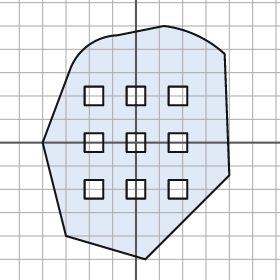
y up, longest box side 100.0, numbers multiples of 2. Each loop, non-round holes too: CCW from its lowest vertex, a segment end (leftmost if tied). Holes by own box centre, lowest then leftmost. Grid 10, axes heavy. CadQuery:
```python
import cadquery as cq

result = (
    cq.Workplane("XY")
    .moveTo(4.0, -50.0)
    .lineTo(40.0, -14.0)
    .lineTo(38.0, 38.0)
    .threePointArc((26.0, 46.0), (12.0, 50.0))
    .lineTo(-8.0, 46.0)
    .threePointArc((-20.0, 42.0), (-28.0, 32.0))
    .lineTo(-40.0, 0.0)
    .lineTo(-30.0, -40.0)
    .close()
    .moveTo(-22.0, -24.0)
    .lineTo(-14.0, -24.0)
    .lineTo(-14.0, -16.0)
    .lineTo(-22.0, -16.0)
    .close()
    .moveTo(-4.0, -24.0)
    .lineTo(4.0, -24.0)
    .lineTo(4.0, -16.0)
    .lineTo(-4.0, -16.0)
    .close()
    .moveTo(14.0, -24.0)
    .lineTo(22.0, -24.0)
    .lineTo(22.0, -16.0)
    .lineTo(14.0, -16.0)
    .close()
    .moveTo(-22.0, -4.0)
    .lineTo(-14.0, -4.0)
    .lineTo(-14.0, 4.0)
    .lineTo(-22.0, 4.0)
    .close()
    .moveTo(-4.0, -4.0)
    .lineTo(4.0, -4.0)
    .lineTo(4.0, 4.0)
    .lineTo(-4.0, 4.0)
    .close()
    .moveTo(14.0, -4.0)
    .lineTo(22.0, -4.0)
    .lineTo(22.0, 4.0)
    .lineTo(14.0, 4.0)
    .close()
    .moveTo(-22.0, 16.0)
    .lineTo(-14.0, 16.0)
    .lineTo(-14.0, 24.0)
    .lineTo(-22.0, 24.0)
    .close()
    .moveTo(-4.0, 16.0)
    .lineTo(4.0, 16.0)
    .lineTo(4.0, 24.0)
    .lineTo(-4.0, 24.0)
    .close()
    .moveTo(14.0, 16.0)
    .lineTo(22.0, 16.0)
    .lineTo(22.0, 24.0)
    .lineTo(14.0, 24.0)
    .close()
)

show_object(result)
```